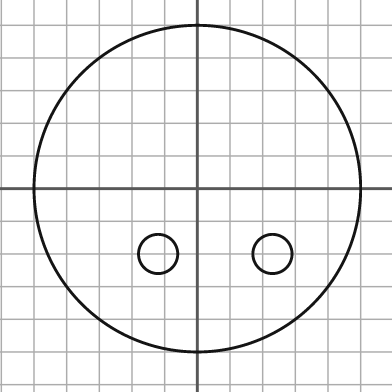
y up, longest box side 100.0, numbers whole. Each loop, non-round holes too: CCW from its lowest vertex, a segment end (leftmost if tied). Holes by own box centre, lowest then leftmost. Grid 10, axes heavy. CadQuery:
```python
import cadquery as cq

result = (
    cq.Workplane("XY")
    .moveTo(0.0, 0.0)
    .circle(50.0)
    .moveTo(-12.0, -20.0)
    .circle(6.0)
    .moveTo(23.0, -20.0)
    .circle(6.0)
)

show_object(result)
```